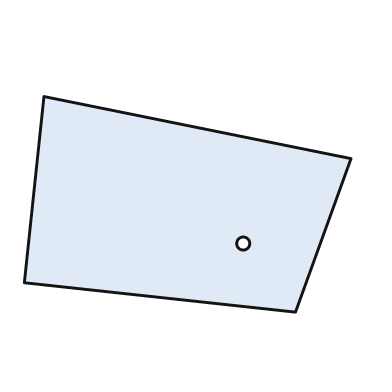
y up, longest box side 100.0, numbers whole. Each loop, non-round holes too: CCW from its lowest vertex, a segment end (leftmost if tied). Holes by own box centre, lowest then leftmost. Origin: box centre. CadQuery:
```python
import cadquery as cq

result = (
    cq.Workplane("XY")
    .moveTo(33.0, -33.0)
    .lineTo(50.0, 14.0)
    .lineTo(-44.0, 33.0)
    .lineTo(-50.0, -24.0)
    .close()
    .moveTo(17.0, -12.0)
    .circle(2.0)
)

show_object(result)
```